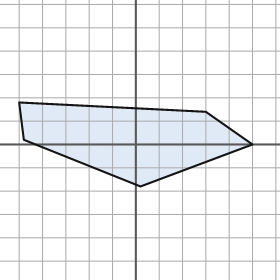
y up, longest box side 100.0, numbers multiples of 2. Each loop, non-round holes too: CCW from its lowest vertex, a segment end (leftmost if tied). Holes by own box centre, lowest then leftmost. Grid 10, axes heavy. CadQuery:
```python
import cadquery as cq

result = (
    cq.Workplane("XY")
    .moveTo(2.0, -18.0)
    .lineTo(50.0, 0.0)
    .lineTo(30.0, 14.0)
    .lineTo(-50.0, 18.0)
    .lineTo(-48.0, 2.0)
    .close()
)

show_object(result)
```